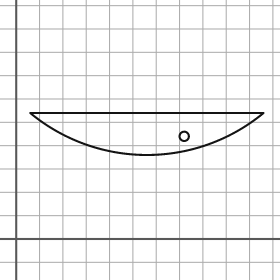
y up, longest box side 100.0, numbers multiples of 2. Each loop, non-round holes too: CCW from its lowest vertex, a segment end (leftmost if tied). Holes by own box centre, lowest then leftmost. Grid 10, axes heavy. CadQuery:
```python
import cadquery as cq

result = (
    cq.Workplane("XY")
    .moveTo(6.0, 54.0)
    .threePointArc((56.0, 36.0), (106.0, 54.0))
    .close()
    .moveTo(72.0, 44.0)
    .circle(2.0)
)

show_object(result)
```